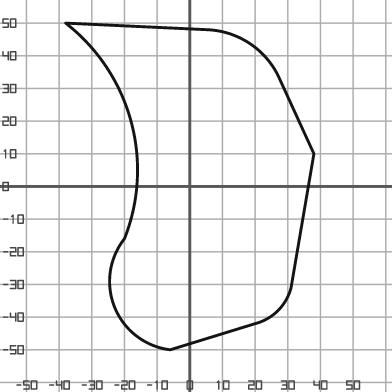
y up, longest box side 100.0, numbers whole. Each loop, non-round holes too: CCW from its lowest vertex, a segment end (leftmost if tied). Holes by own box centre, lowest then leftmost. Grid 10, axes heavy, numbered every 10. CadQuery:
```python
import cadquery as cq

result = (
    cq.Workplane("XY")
    .moveTo(-6.0, -50.0)
    .lineTo(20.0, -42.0)
    .threePointArc((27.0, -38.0), (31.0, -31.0))
    .lineTo(38.0, 10.0)
    .lineTo(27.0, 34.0)
    .threePointArc((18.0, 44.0), (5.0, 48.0))
    .lineTo(-38.0, 50.0)
    .threePointArc((-18.0, 20.0), (-20.0, -16.0))
    .threePointArc((-23.0, -37.0), (-6.0, -50.0))
    .close()
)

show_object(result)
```